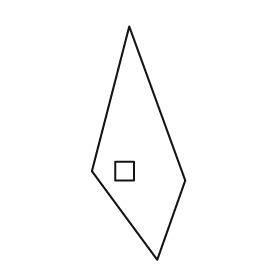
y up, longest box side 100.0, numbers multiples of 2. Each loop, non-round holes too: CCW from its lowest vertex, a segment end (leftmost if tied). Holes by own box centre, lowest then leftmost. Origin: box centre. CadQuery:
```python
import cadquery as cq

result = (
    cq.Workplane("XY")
    .moveTo(8.0, -50.0)
    .lineTo(20.0, -16.0)
    .lineTo(-4.0, 50.0)
    .lineTo(-20.0, -12.0)
    .close()
    .moveTo(-10.0, -16.0)
    .lineTo(-2.0, -16.0)
    .lineTo(-2.0, -8.0)
    .lineTo(-10.0, -8.0)
    .close()
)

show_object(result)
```